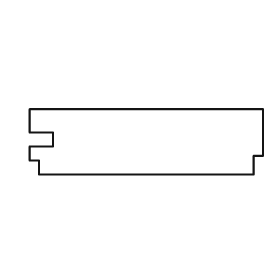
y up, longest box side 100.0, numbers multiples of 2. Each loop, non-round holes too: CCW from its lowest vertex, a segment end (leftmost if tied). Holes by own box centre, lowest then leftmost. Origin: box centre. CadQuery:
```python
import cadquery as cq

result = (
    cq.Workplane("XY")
    .moveTo(-46.0, -14.0)
    .lineTo(46.0, -14.0)
    .lineTo(46.0, -6.0)
    .lineTo(50.0, -6.0)
    .lineTo(50.0, 14.0)
    .lineTo(-50.0, 14.0)
    .lineTo(-50.0, 4.0)
    .lineTo(-40.0, 4.0)
    .lineTo(-40.0, -2.0)
    .lineTo(-50.0, -2.0)
    .lineTo(-50.0, -8.0)
    .lineTo(-46.0, -8.0)
    .close()
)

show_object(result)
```